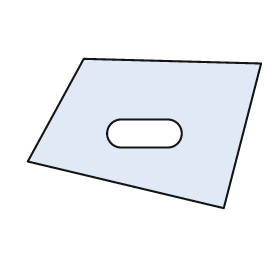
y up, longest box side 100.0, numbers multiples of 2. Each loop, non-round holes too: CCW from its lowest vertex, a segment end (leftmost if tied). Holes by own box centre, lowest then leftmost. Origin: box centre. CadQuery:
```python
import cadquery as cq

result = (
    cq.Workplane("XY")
    .moveTo(34.0, -32.0)
    .lineTo(50.0, 30.0)
    .lineTo(-26.0, 32.0)
    .lineTo(-50.0, -12.0)
    .close()
    .moveTo(-10.0, -6.0)
    .lineTo(10.0, -6.0)
    .threePointArc((16.0, 0.0), (10.0, 6.0))
    .lineTo(-10.0, 6.0)
    .threePointArc((-16.0, 0.0), (-10.0, -6.0))
    .close()
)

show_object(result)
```